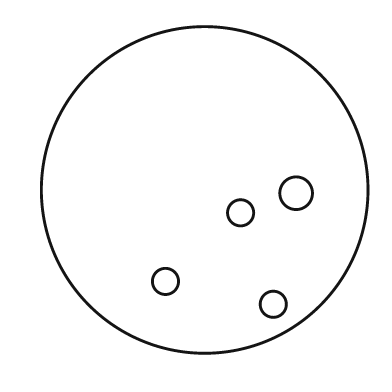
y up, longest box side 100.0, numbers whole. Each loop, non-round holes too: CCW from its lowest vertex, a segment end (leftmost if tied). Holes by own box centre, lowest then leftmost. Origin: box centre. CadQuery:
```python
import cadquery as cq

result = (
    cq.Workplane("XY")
    .moveTo(0.0, 0.0)
    .circle(50.0)
    .moveTo(21.0, -35.0)
    .circle(4.0)
    .moveTo(-12.0, -28.0)
    .circle(4.0)
    .moveTo(11.0, -7.0)
    .circle(4.0)
    .moveTo(28.0, -1.0)
    .circle(5.0)
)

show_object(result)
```